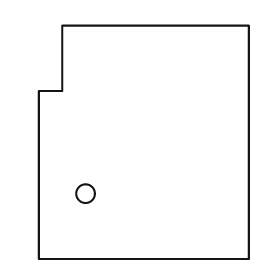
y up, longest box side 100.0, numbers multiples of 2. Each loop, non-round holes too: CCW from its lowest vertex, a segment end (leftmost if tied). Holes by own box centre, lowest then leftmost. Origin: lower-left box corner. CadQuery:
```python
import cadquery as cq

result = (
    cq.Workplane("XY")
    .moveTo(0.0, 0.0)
    .lineTo(90.0, 0.0)
    .lineTo(90.0, 100.0)
    .lineTo(10.0, 100.0)
    .lineTo(10.0, 72.0)
    .lineTo(0.0, 72.0)
    .close()
    .moveTo(20.0, 28.0)
    .circle(4.0)
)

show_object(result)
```